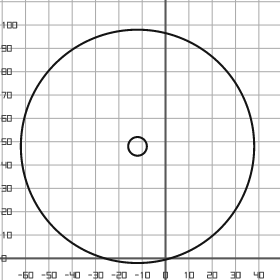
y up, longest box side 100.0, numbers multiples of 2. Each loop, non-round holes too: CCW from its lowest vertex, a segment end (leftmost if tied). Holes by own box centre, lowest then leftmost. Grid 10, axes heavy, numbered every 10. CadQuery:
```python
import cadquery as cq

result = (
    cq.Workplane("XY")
    .moveTo(-12.0, 48.0)
    .circle(50.0)
    .moveTo(-12.0, 48.0)
    .circle(4.0)
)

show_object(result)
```